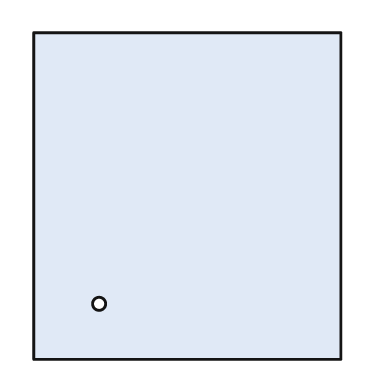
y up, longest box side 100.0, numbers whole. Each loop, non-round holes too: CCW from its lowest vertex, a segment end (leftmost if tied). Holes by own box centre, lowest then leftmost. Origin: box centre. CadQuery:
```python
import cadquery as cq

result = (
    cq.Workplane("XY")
    .moveTo(-47.0, -50.0)
    .lineTo(47.0, -50.0)
    .lineTo(47.0, 50.0)
    .lineTo(-47.0, 50.0)
    .close()
    .moveTo(-27.0, -33.0)
    .circle(2.0)
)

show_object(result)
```